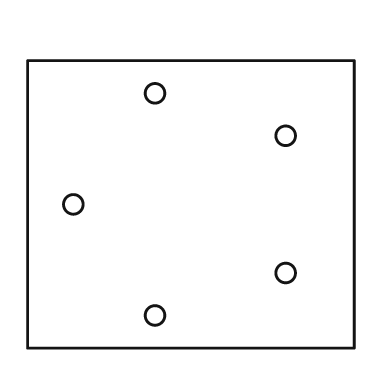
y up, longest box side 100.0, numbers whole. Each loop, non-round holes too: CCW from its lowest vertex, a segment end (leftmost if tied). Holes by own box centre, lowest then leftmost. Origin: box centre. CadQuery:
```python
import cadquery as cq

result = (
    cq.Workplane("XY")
    .moveTo(-50.0, -44.0)
    .lineTo(50.0, -44.0)
    .lineTo(50.0, 44.0)
    .lineTo(-50.0, 44.0)
    .close()
    .moveTo(-11.0, -34.0)
    .circle(3.0)
    .moveTo(29.0, -21.0)
    .circle(3.0)
    .moveTo(-36.0, 0.0)
    .circle(3.0)
    .moveTo(29.0, 21.0)
    .circle(3.0)
    .moveTo(-11.0, 34.0)
    .circle(3.0)
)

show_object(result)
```